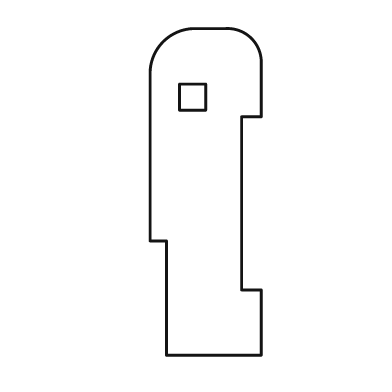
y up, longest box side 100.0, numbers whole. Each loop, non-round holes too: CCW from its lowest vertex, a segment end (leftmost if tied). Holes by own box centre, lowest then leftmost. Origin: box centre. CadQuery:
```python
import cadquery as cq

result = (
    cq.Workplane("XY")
    .moveTo(-12.0, -50.0)
    .lineTo(17.0, -50.0)
    .lineTo(17.0, -30.0)
    .lineTo(11.0, -30.0)
    .lineTo(11.0, 23.0)
    .lineTo(17.0, 23.0)
    .lineTo(17.0, 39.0)
    .threePointArc((14.0, 47.0), (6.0, 50.0))
    .lineTo(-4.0, 50.0)
    .threePointArc((-13.0, 46.0), (-17.0, 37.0))
    .lineTo(-17.0, -15.0)
    .lineTo(-12.0, -15.0)
    .close()
    .moveTo(-8.0, 25.0)
    .lineTo(0.0, 25.0)
    .lineTo(0.0, 33.0)
    .lineTo(-8.0, 33.0)
    .close()
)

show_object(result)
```